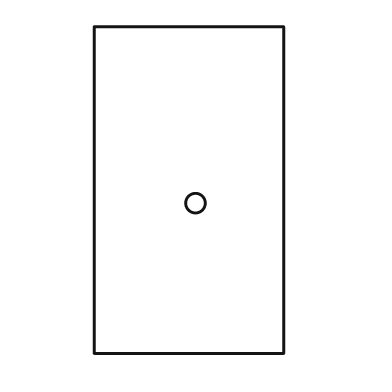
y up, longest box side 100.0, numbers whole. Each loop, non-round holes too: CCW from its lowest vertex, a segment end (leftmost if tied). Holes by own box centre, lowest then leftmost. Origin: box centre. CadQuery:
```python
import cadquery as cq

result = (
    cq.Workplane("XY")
    .moveTo(-29.0, -50.0)
    .lineTo(29.0, -50.0)
    .lineTo(29.0, 50.0)
    .lineTo(-29.0, 50.0)
    .close()
    .moveTo(2.0, -4.0)
    .circle(3.0)
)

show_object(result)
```